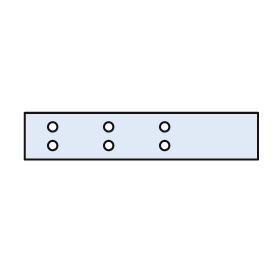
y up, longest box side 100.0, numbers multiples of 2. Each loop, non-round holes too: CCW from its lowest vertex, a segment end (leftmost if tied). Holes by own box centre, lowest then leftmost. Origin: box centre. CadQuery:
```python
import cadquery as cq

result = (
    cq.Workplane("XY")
    .moveTo(-50.0, -10.0)
    .lineTo(50.0, -10.0)
    .lineTo(50.0, 10.0)
    .lineTo(-50.0, 10.0)
    .close()
    .moveTo(-38.0, -4.0)
    .circle(2.0)
    .moveTo(-14.0, -4.0)
    .circle(2.0)
    .moveTo(10.0, -4.0)
    .circle(2.0)
    .moveTo(-38.0, 4.0)
    .circle(2.0)
    .moveTo(-14.0, 4.0)
    .circle(2.0)
    .moveTo(10.0, 4.0)
    .circle(2.0)
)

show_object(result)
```